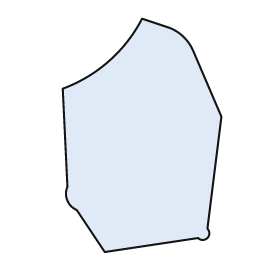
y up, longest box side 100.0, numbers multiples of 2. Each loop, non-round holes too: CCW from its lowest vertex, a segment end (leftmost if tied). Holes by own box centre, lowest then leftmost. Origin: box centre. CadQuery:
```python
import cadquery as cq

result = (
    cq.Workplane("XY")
    .moveTo(-16.0, -50.0)
    .lineTo(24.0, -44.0)
    .threePointArc((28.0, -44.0), (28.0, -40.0))
    .lineTo(34.0, 8.0)
    .lineTo(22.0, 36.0)
    .threePointArc((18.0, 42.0), (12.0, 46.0))
    .lineTo(0.0, 50.0)
    .threePointArc((-14.0, 32.0), (-34.0, 20.0))
    .lineTo(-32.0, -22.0)
    .threePointArc((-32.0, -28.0), (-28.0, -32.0))
    .close()
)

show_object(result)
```